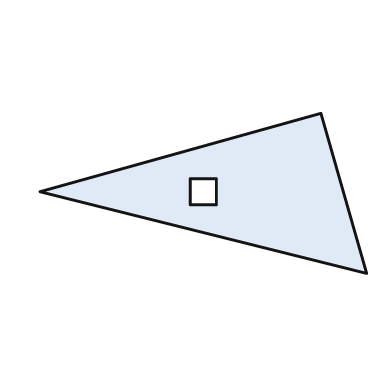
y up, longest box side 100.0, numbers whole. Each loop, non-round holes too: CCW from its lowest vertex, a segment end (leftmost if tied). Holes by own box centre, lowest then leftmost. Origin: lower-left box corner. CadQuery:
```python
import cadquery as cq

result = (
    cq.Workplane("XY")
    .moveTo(100.0, 0.0)
    .lineTo(86.0, 49.0)
    .lineTo(0.0, 25.0)
    .close()
    .moveTo(46.0, 21.0)
    .lineTo(54.0, 21.0)
    .lineTo(54.0, 29.0)
    .lineTo(46.0, 29.0)
    .close()
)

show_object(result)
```